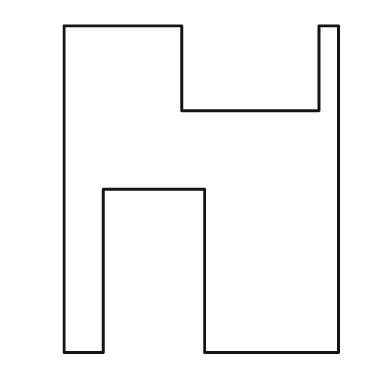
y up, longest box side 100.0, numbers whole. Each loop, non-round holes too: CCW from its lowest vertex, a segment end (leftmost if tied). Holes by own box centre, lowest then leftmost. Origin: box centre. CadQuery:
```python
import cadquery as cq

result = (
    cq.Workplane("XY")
    .moveTo(-42.0, -50.0)
    .lineTo(-30.0, -50.0)
    .lineTo(-30.0, 0.0)
    .lineTo(1.0, 0.0)
    .lineTo(1.0, -50.0)
    .lineTo(42.0, -50.0)
    .lineTo(42.0, 50.0)
    .lineTo(36.0, 50.0)
    .lineTo(36.0, 24.0)
    .lineTo(-6.0, 24.0)
    .lineTo(-6.0, 50.0)
    .lineTo(-42.0, 50.0)
    .close()
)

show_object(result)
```